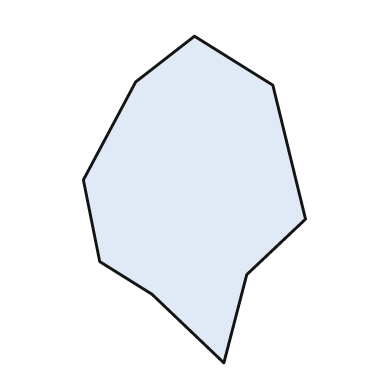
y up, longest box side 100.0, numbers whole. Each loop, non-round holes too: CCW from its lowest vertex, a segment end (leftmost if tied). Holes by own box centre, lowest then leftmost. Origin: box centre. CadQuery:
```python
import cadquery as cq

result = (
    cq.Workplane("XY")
    .moveTo(9.0, -50.0)
    .lineTo(16.0, -23.0)
    .lineTo(34.0, -6.0)
    .lineTo(24.0, 35.0)
    .lineTo(0.0, 50.0)
    .lineTo(-18.0, 36.0)
    .lineTo(-34.0, 6.0)
    .lineTo(-29.0, -19.0)
    .lineTo(-13.0, -29.0)
    .close()
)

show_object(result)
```